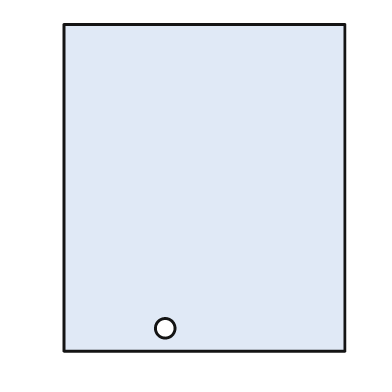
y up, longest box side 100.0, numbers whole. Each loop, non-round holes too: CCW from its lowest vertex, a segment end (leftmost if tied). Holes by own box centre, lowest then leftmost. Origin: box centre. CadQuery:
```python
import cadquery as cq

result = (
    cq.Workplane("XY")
    .moveTo(-43.0, -50.0)
    .lineTo(43.0, -50.0)
    .lineTo(43.0, 50.0)
    .lineTo(-43.0, 50.0)
    .close()
    .moveTo(-12.0, -43.0)
    .circle(3.0)
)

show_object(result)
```